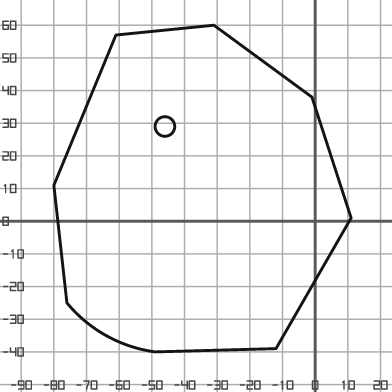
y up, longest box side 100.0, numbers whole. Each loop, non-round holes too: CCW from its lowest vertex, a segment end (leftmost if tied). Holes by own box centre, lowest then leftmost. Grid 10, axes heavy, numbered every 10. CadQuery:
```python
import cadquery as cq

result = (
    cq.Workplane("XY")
    .moveTo(-49.0, -40.0)
    .lineTo(-12.0, -39.0)
    .lineTo(11.0, 1.0)
    .lineTo(-1.0, 38.0)
    .lineTo(-31.0, 60.0)
    .lineTo(-61.0, 57.0)
    .lineTo(-80.0, 11.0)
    .lineTo(-76.0, -25.0)
    .threePointArc((-64.0, -35.0), (-49.0, -40.0))
    .close()
    .moveTo(-46.0, 29.0)
    .circle(3.0)
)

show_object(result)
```